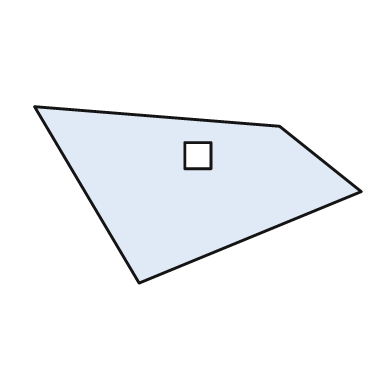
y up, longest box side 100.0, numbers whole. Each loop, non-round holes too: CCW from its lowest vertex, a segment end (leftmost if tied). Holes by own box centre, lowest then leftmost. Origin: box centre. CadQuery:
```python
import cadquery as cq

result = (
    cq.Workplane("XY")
    .moveTo(-18.0, -27.0)
    .lineTo(50.0, 1.0)
    .lineTo(25.0, 21.0)
    .lineTo(-50.0, 27.0)
    .close()
    .moveTo(-4.0, 8.0)
    .lineTo(4.0, 8.0)
    .lineTo(4.0, 16.0)
    .lineTo(-4.0, 16.0)
    .close()
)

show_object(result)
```